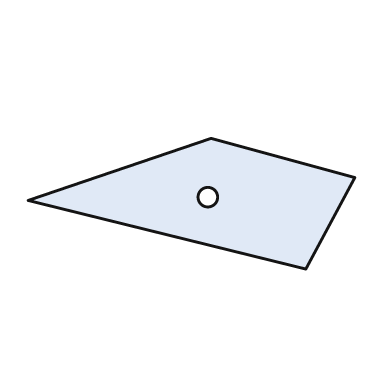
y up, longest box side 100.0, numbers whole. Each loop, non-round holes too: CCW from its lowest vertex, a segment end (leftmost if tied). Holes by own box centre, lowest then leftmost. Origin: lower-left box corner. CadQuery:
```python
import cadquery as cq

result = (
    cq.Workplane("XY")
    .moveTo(85.0, 0.0)
    .lineTo(100.0, 28.0)
    .lineTo(56.0, 40.0)
    .lineTo(0.0, 21.0)
    .close()
    .moveTo(55.0, 22.0)
    .circle(3.0)
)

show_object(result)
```